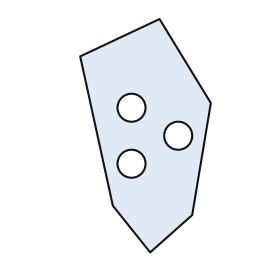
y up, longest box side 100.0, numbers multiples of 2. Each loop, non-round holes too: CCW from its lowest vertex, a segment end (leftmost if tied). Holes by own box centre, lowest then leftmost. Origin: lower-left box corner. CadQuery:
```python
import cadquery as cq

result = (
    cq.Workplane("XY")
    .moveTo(30.0, 0.0)
    .lineTo(48.0, 16.0)
    .lineTo(56.0, 64.0)
    .lineTo(34.0, 100.0)
    .lineTo(0.0, 84.0)
    .lineTo(14.0, 20.0)
    .close()
    .moveTo(22.0, 38.0)
    .circle(6.0)
    .moveTo(42.0, 50.0)
    .circle(6.0)
    .moveTo(22.0, 62.0)
    .circle(6.0)
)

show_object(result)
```